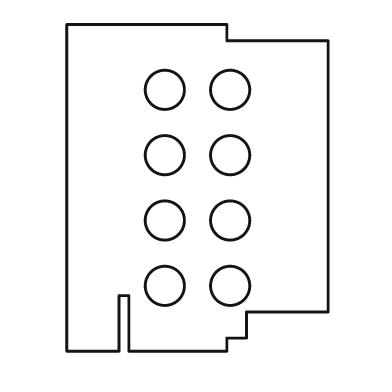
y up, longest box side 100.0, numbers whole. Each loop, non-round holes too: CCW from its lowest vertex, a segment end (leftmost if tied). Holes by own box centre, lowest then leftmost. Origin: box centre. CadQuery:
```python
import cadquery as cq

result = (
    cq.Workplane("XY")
    .moveTo(-40.0, -50.0)
    .lineTo(-24.0, -50.0)
    .lineTo(-24.0, -33.0)
    .lineTo(-21.0, -33.0)
    .lineTo(-21.0, -50.0)
    .lineTo(9.0, -50.0)
    .lineTo(9.0, -46.0)
    .lineTo(15.0, -46.0)
    .lineTo(15.0, -38.0)
    .lineTo(40.0, -38.0)
    .lineTo(40.0, 45.0)
    .lineTo(9.0, 45.0)
    .lineTo(9.0, 50.0)
    .lineTo(-40.0, 50.0)
    .close()
    .moveTo(-10.0, -30.0)
    .circle(6.0)
    .moveTo(10.0, -30.0)
    .circle(6.0)
    .moveTo(-10.0, -10.0)
    .circle(6.0)
    .moveTo(10.0, -10.0)
    .circle(6.0)
    .moveTo(-10.0, 10.0)
    .circle(6.0)
    .moveTo(10.0, 10.0)
    .circle(6.0)
    .moveTo(-10.0, 30.0)
    .circle(6.0)
    .moveTo(10.0, 30.0)
    .circle(6.0)
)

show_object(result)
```